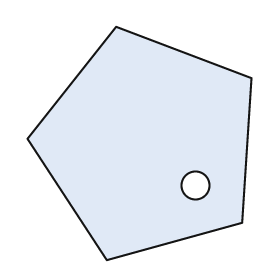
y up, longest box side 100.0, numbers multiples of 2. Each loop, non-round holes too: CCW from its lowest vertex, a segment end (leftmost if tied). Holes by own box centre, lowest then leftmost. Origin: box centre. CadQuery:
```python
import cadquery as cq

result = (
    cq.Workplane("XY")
    .moveTo(-14.0, -50.0)
    .lineTo(44.0, -34.0)
    .lineTo(48.0, 28.0)
    .lineTo(-10.0, 50.0)
    .lineTo(-48.0, 2.0)
    .close()
    .moveTo(24.0, -18.0)
    .circle(6.0)
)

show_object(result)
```